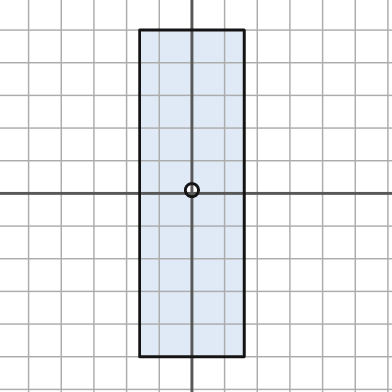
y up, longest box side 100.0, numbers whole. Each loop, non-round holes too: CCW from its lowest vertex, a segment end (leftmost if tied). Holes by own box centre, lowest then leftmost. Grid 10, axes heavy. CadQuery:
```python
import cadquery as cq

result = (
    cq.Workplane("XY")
    .moveTo(-16.0, -50.0)
    .lineTo(16.0, -50.0)
    .lineTo(16.0, 50.0)
    .lineTo(-16.0, 50.0)
    .close()
    .moveTo(0.0, 1.0)
    .circle(2.0)
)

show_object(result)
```